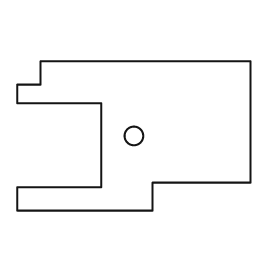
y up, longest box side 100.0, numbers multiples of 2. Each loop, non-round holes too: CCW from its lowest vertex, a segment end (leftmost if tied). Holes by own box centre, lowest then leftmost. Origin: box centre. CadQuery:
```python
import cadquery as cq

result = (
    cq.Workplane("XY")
    .moveTo(-50.0, -32.0)
    .lineTo(8.0, -32.0)
    .lineTo(8.0, -20.0)
    .lineTo(50.0, -20.0)
    .lineTo(50.0, 32.0)
    .lineTo(-40.0, 32.0)
    .lineTo(-40.0, 22.0)
    .lineTo(-50.0, 22.0)
    .lineTo(-50.0, 14.0)
    .lineTo(-14.0, 14.0)
    .lineTo(-14.0, -22.0)
    .lineTo(-50.0, -22.0)
    .close()
    .moveTo(0.0, 0.0)
    .circle(4.0)
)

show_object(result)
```